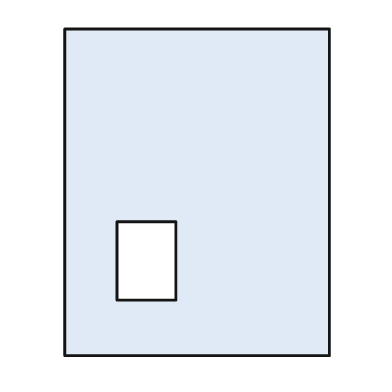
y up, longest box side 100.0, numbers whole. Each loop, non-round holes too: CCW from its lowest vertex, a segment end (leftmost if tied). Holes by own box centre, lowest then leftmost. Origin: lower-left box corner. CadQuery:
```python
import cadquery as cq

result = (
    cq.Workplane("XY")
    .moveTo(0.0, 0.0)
    .lineTo(81.0, 0.0)
    .lineTo(81.0, 100.0)
    .lineTo(0.0, 100.0)
    .close()
    .moveTo(16.0, 17.0)
    .lineTo(34.0, 17.0)
    .lineTo(34.0, 41.0)
    .lineTo(16.0, 41.0)
    .close()
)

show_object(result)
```